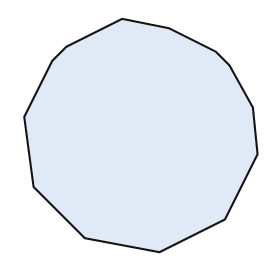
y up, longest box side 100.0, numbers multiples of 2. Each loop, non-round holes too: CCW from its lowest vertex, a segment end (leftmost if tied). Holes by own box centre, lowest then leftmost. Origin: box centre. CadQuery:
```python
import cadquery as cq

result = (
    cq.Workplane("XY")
    .moveTo(8.0, -50.0)
    .lineTo(36.0, -36.0)
    .lineTo(50.0, -8.0)
    .lineTo(48.0, 12.0)
    .lineTo(38.0, 30.0)
    .lineTo(32.0, 36.0)
    .lineTo(12.0, 46.0)
    .lineTo(-8.0, 50.0)
    .lineTo(-32.0, 38.0)
    .lineTo(-38.0, 32.0)
    .lineTo(-50.0, 8.0)
    .lineTo(-46.0, -22.0)
    .lineTo(-24.0, -44.0)
    .close()
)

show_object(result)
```